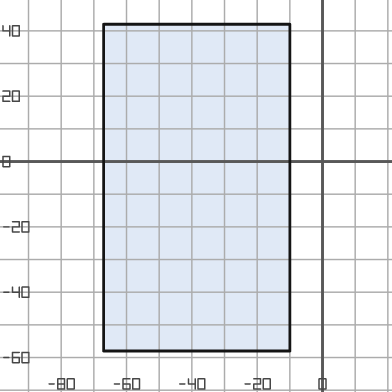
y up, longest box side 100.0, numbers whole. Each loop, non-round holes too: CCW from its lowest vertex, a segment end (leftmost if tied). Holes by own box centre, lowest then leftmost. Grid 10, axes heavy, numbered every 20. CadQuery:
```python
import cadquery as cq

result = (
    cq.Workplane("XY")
    .moveTo(-67.0, -58.0)
    .lineTo(-10.0, -58.0)
    .lineTo(-10.0, 42.0)
    .lineTo(-67.0, 42.0)
    .close()
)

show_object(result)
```